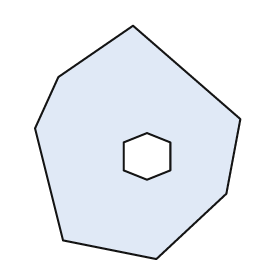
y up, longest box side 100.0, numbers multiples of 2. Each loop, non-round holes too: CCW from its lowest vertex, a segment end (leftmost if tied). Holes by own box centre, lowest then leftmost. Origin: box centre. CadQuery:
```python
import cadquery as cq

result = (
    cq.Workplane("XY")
    .moveTo(8.0, -50.0)
    .lineTo(38.0, -22.0)
    .lineTo(44.0, 10.0)
    .lineTo(-2.0, 50.0)
    .lineTo(-34.0, 28.0)
    .lineTo(-44.0, 6.0)
    .lineTo(-32.0, -42.0)
    .close()
    .moveTo(4.0, -16.0)
    .lineTo(14.0, -12.0)
    .lineTo(14.0, 0.0)
    .lineTo(4.0, 4.0)
    .lineTo(-6.0, 0.0)
    .lineTo(-6.0, -12.0)
    .close()
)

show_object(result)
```